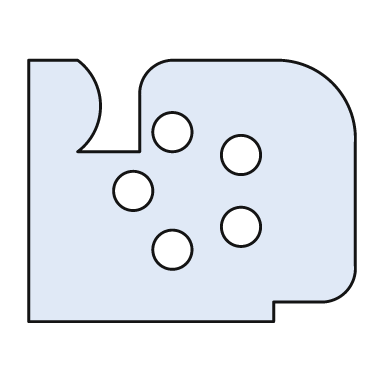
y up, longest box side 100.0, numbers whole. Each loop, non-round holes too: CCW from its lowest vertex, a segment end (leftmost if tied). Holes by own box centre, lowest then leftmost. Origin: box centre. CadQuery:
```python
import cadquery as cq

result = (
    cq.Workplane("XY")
    .moveTo(-50.0, -40.0)
    .lineTo(25.0, -40.0)
    .lineTo(25.0, -34.0)
    .lineTo(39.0, -34.0)
    .threePointArc((47.0, -31.0), (50.0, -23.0))
    .lineTo(50.0, 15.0)
    .threePointArc((43.0, 33.0), (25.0, 40.0))
    .lineTo(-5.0, 40.0)
    .threePointArc((-13.0, 37.0), (-16.0, 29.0))
    .lineTo(-16.0, 12.0)
    .lineTo(-35.0, 12.0)
    .threePointArc((-28.0, 26.0), (-35.0, 40.0))
    .lineTo(-50.0, 40.0)
    .close()
    .moveTo(-6.0, -18.0)
    .circle(6.0)
    .moveTo(15.0, -11.0)
    .circle(6.0)
    .moveTo(-18.0, 0.0)
    .circle(6.0)
    .moveTo(15.0, 11.0)
    .circle(6.0)
    .moveTo(-6.0, 18.0)
    .circle(6.0)
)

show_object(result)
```